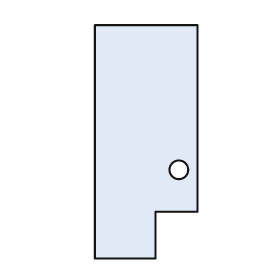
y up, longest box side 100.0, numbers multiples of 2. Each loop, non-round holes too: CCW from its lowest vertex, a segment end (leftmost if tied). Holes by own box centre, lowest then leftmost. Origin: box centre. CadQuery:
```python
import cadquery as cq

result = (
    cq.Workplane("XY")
    .moveTo(-22.0, -50.0)
    .lineTo(4.0, -50.0)
    .lineTo(4.0, -30.0)
    .lineTo(22.0, -30.0)
    .lineTo(22.0, 50.0)
    .lineTo(-22.0, 50.0)
    .close()
    .moveTo(14.0, -12.0)
    .circle(4.0)
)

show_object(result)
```